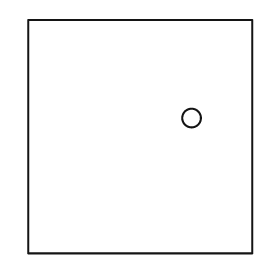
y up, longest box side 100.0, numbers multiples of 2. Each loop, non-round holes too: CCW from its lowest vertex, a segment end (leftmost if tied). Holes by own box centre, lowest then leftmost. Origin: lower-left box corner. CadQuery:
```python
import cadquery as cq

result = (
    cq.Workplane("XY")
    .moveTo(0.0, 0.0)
    .lineTo(96.0, 0.0)
    .lineTo(96.0, 100.0)
    .lineTo(0.0, 100.0)
    .close()
    .moveTo(70.0, 58.0)
    .circle(4.0)
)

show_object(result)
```